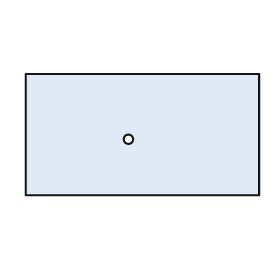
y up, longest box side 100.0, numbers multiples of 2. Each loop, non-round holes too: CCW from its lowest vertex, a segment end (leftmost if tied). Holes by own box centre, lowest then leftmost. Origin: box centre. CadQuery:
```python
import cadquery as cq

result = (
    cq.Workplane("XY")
    .moveTo(-50.0, -26.0)
    .lineTo(50.0, -26.0)
    .lineTo(50.0, 26.0)
    .lineTo(-50.0, 26.0)
    .close()
    .moveTo(-6.0, -2.0)
    .circle(2.0)
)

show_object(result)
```